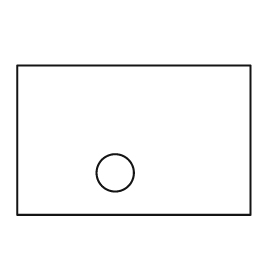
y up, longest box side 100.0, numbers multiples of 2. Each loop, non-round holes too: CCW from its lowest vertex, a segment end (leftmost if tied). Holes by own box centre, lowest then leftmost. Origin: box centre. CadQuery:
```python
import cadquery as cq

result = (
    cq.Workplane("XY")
    .moveTo(-50.0, -32.0)
    .lineTo(50.0, -32.0)
    .lineTo(50.0, 32.0)
    .lineTo(-50.0, 32.0)
    .close()
    .moveTo(-8.0, -14.0)
    .circle(8.0)
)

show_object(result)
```